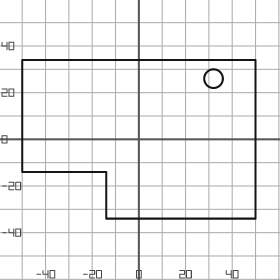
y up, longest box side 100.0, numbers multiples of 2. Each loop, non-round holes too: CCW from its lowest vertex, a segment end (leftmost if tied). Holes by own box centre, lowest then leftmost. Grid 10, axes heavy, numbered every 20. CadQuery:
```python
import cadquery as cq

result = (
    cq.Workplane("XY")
    .moveTo(-14.0, -34.0)
    .lineTo(50.0, -34.0)
    .lineTo(50.0, 34.0)
    .lineTo(-50.0, 34.0)
    .lineTo(-50.0, -14.0)
    .lineTo(-14.0, -14.0)
    .close()
    .moveTo(32.0, 26.0)
    .circle(4.0)
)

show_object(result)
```